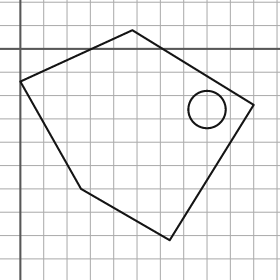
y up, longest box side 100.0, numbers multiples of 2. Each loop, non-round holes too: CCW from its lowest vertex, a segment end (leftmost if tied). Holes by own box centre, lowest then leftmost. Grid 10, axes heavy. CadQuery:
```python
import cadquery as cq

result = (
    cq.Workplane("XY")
    .moveTo(64.0, -82.0)
    .lineTo(100.0, -24.0)
    .lineTo(48.0, 8.0)
    .lineTo(0.0, -14.0)
    .lineTo(26.0, -60.0)
    .close()
    .moveTo(80.0, -26.0)
    .circle(8.0)
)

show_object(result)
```